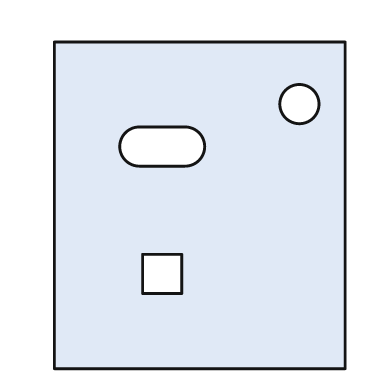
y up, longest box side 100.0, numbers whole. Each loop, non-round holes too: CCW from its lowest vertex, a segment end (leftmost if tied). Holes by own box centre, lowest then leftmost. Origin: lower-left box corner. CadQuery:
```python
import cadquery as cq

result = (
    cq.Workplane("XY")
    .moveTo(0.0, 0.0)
    .lineTo(89.0, 0.0)
    .lineTo(89.0, 100.0)
    .lineTo(0.0, 100.0)
    .close()
    .moveTo(27.0, 23.0)
    .lineTo(39.0, 23.0)
    .lineTo(39.0, 35.0)
    .lineTo(27.0, 35.0)
    .close()
    .moveTo(26.0, 62.0)
    .lineTo(40.0, 62.0)
    .threePointArc((46.0, 68.0), (40.0, 74.0))
    .lineTo(26.0, 74.0)
    .threePointArc((20.0, 68.0), (26.0, 62.0))
    .close()
    .moveTo(75.0, 81.0)
    .circle(6.0)
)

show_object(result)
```